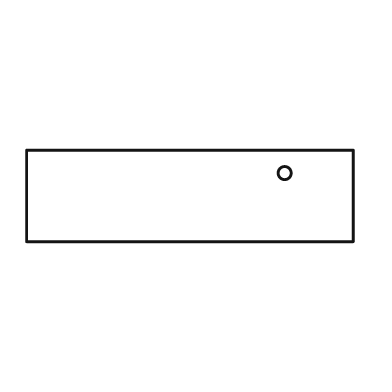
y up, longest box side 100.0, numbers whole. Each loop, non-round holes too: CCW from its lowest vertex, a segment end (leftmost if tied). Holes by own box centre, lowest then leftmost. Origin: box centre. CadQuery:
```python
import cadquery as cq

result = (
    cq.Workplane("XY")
    .moveTo(-50.0, -14.0)
    .lineTo(50.0, -14.0)
    .lineTo(50.0, 14.0)
    .lineTo(-50.0, 14.0)
    .close()
    .moveTo(29.0, 7.0)
    .circle(2.0)
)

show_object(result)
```